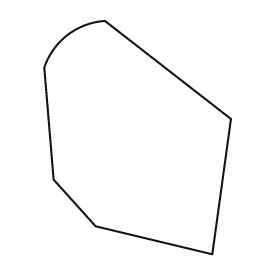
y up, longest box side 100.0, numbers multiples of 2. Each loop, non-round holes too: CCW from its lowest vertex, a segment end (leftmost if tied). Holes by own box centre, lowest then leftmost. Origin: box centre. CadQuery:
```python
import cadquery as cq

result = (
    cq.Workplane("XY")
    .moveTo(32.0, -50.0)
    .lineTo(40.0, 8.0)
    .lineTo(-14.0, 50.0)
    .threePointArc((-30.0, 44.0), (-40.0, 30.0))
    .lineTo(-36.0, -18.0)
    .lineTo(-18.0, -38.0)
    .close()
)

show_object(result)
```